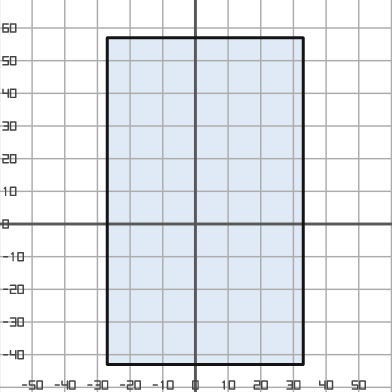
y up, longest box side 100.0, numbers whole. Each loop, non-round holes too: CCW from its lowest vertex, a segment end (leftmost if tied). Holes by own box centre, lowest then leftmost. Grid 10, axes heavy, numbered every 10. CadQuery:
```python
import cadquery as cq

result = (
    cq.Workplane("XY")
    .moveTo(-27.0, -43.0)
    .lineTo(33.0, -43.0)
    .lineTo(33.0, 57.0)
    .lineTo(-27.0, 57.0)
    .close()
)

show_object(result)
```